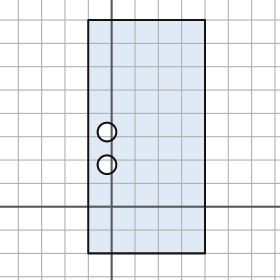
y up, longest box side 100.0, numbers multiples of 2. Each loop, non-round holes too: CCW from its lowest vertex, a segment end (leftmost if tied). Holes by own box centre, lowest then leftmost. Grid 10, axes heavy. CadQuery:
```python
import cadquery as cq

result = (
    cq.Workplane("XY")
    .moveTo(-10.0, -20.0)
    .lineTo(40.0, -20.0)
    .lineTo(40.0, 80.0)
    .lineTo(-10.0, 80.0)
    .close()
    .moveTo(-2.0, 18.0)
    .circle(4.0)
    .moveTo(-2.0, 32.0)
    .circle(4.0)
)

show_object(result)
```